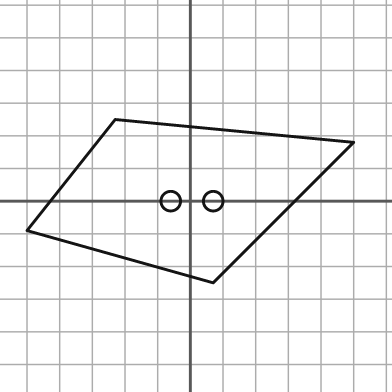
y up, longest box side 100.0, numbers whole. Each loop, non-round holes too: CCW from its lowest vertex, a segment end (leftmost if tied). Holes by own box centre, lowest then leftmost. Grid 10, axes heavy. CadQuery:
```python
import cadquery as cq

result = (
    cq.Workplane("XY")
    .moveTo(7.0, -25.0)
    .lineTo(50.0, 18.0)
    .lineTo(-23.0, 25.0)
    .lineTo(-50.0, -9.0)
    .close()
    .moveTo(-6.0, 0.0)
    .circle(3.0)
    .moveTo(7.0, 0.0)
    .circle(3.0)
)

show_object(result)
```